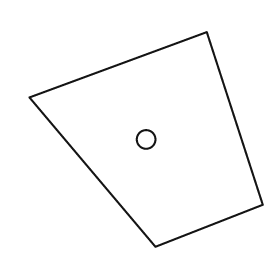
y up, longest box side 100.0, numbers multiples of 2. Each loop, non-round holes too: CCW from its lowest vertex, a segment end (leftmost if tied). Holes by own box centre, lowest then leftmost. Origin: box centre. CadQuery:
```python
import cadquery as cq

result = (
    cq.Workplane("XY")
    .moveTo(4.0, -46.0)
    .lineTo(50.0, -28.0)
    .lineTo(26.0, 46.0)
    .lineTo(-50.0, 18.0)
    .close()
    .moveTo(0.0, 0.0)
    .circle(4.0)
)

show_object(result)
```